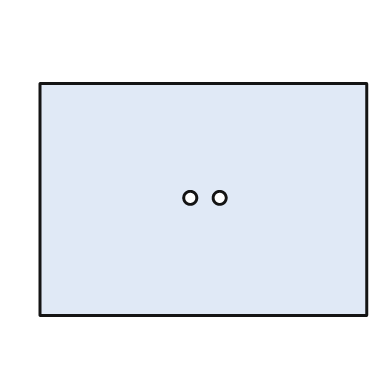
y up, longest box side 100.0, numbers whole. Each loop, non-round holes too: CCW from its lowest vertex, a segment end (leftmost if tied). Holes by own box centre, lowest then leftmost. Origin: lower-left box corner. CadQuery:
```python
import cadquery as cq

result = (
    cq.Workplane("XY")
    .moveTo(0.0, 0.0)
    .lineTo(100.0, 0.0)
    .lineTo(100.0, 71.0)
    .lineTo(0.0, 71.0)
    .close()
    .moveTo(46.0, 36.0)
    .circle(2.0)
    .moveTo(55.0, 36.0)
    .circle(2.0)
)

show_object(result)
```